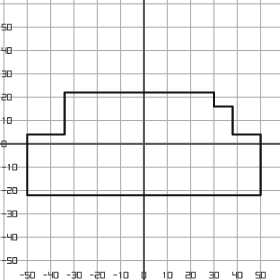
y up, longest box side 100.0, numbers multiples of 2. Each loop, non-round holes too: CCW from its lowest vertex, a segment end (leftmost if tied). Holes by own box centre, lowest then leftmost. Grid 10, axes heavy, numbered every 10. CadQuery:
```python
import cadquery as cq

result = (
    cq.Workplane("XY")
    .moveTo(-50.0, -22.0)
    .lineTo(50.0, -22.0)
    .lineTo(50.0, 4.0)
    .lineTo(38.0, 4.0)
    .lineTo(38.0, 16.0)
    .lineTo(30.0, 16.0)
    .lineTo(30.0, 22.0)
    .lineTo(-34.0, 22.0)
    .lineTo(-34.0, 4.0)
    .lineTo(-50.0, 4.0)
    .close()
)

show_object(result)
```